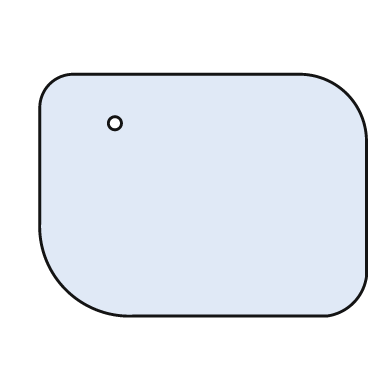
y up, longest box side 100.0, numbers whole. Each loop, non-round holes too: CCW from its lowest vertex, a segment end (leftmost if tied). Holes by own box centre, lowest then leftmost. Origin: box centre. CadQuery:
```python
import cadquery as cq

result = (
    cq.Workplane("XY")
    .moveTo(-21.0, -37.0)
    .lineTo(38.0, -37.0)
    .threePointArc((46.0, -33.0), (50.0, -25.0))
    .lineTo(50.0, 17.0)
    .threePointArc((44.0, 31.0), (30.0, 37.0))
    .lineTo(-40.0, 37.0)
    .threePointArc((-47.0, 34.0), (-50.0, 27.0))
    .lineTo(-50.0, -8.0)
    .threePointArc((-42.0, -29.0), (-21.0, -37.0))
    .close()
    .moveTo(-27.0, 22.0)
    .circle(2.0)
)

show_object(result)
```